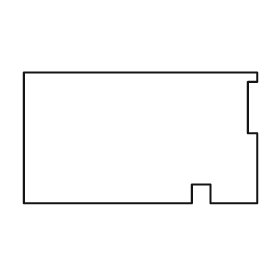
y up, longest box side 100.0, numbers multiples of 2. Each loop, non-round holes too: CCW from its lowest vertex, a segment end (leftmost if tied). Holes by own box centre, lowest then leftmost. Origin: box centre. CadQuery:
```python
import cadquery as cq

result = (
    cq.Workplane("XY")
    .moveTo(-50.0, -28.0)
    .lineTo(22.0, -28.0)
    .lineTo(22.0, -20.0)
    .lineTo(30.0, -20.0)
    .lineTo(30.0, -28.0)
    .lineTo(50.0, -28.0)
    .lineTo(50.0, 2.0)
    .lineTo(46.0, 2.0)
    .lineTo(46.0, 24.0)
    .lineTo(50.0, 24.0)
    .lineTo(50.0, 28.0)
    .lineTo(-50.0, 28.0)
    .close()
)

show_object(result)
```